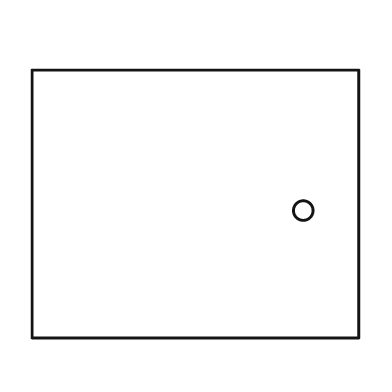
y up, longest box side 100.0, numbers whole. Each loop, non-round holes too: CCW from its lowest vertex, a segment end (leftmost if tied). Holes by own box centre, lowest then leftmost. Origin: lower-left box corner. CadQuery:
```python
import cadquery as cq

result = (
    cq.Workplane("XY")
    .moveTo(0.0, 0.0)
    .lineTo(100.0, 0.0)
    .lineTo(100.0, 82.0)
    .lineTo(0.0, 82.0)
    .close()
    .moveTo(83.0, 39.0)
    .circle(3.0)
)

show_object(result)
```